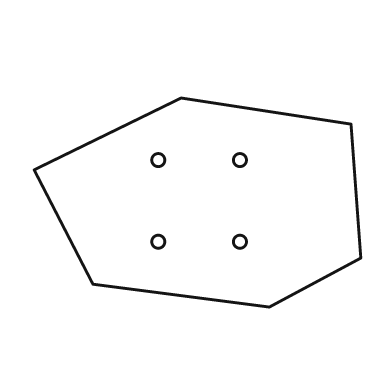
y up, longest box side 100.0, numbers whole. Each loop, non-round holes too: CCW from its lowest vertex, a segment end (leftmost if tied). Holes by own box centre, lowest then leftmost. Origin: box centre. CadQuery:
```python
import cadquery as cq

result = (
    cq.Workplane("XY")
    .moveTo(22.0, -32.0)
    .lineTo(50.0, -17.0)
    .lineTo(47.0, 24.0)
    .lineTo(-5.0, 32.0)
    .lineTo(-50.0, 10.0)
    .lineTo(-32.0, -25.0)
    .close()
    .moveTo(-12.0, -12.0)
    .circle(2.0)
    .moveTo(13.0, -12.0)
    .circle(2.0)
    .moveTo(-12.0, 13.0)
    .circle(2.0)
    .moveTo(13.0, 13.0)
    .circle(2.0)
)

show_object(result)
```